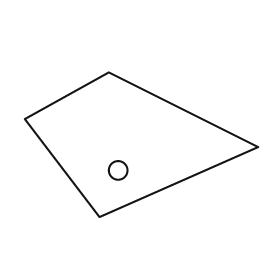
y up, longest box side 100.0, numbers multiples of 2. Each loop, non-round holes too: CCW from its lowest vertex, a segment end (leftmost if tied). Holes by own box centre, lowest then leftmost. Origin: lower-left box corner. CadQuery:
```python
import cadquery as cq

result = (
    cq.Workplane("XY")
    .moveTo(32.0, 0.0)
    .lineTo(100.0, 30.0)
    .lineTo(36.0, 62.0)
    .lineTo(0.0, 42.0)
    .close()
    .moveTo(40.0, 20.0)
    .circle(4.0)
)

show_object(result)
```